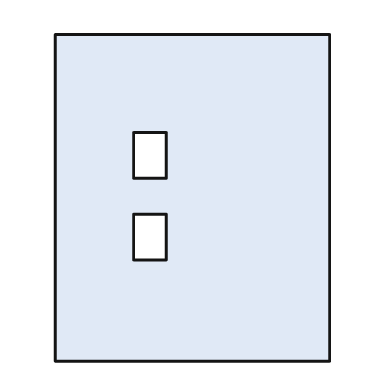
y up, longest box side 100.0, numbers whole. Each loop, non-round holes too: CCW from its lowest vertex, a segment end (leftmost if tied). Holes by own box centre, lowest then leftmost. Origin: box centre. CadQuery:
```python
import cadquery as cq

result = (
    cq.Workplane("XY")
    .moveTo(-42.0, -50.0)
    .lineTo(42.0, -50.0)
    .lineTo(42.0, 50.0)
    .lineTo(-42.0, 50.0)
    .close()
    .moveTo(-18.0, -19.0)
    .lineTo(-8.0, -19.0)
    .lineTo(-8.0, -5.0)
    .lineTo(-18.0, -5.0)
    .close()
    .moveTo(-18.0, 6.0)
    .lineTo(-8.0, 6.0)
    .lineTo(-8.0, 20.0)
    .lineTo(-18.0, 20.0)
    .close()
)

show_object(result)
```